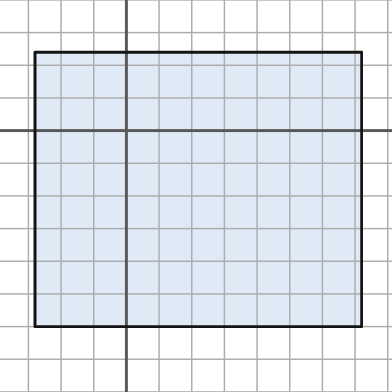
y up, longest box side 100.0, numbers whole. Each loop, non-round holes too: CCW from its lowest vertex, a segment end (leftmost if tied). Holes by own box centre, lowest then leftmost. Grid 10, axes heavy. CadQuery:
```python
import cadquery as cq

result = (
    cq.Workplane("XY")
    .moveTo(-28.0, -60.0)
    .lineTo(72.0, -60.0)
    .lineTo(72.0, 24.0)
    .lineTo(-28.0, 24.0)
    .close()
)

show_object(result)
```